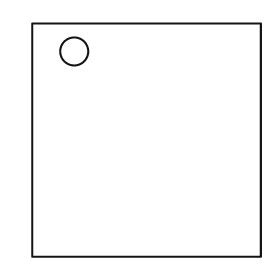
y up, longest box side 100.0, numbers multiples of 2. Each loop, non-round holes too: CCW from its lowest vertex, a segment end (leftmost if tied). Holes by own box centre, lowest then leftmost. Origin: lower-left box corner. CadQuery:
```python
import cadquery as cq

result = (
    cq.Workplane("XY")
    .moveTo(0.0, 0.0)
    .lineTo(98.0, 0.0)
    .lineTo(98.0, 100.0)
    .lineTo(0.0, 100.0)
    .close()
    .moveTo(18.0, 88.0)
    .circle(6.0)
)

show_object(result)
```